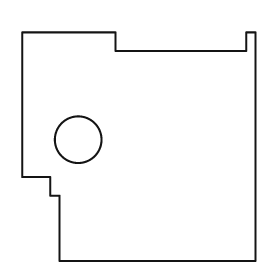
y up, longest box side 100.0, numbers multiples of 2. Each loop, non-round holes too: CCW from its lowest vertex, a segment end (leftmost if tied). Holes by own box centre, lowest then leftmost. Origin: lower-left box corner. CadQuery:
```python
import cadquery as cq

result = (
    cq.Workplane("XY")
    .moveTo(16.0, 0.0)
    .lineTo(100.0, 0.0)
    .lineTo(100.0, 98.0)
    .lineTo(96.0, 98.0)
    .lineTo(96.0, 90.0)
    .lineTo(40.0, 90.0)
    .lineTo(40.0, 98.0)
    .lineTo(0.0, 98.0)
    .lineTo(0.0, 36.0)
    .lineTo(12.0, 36.0)
    .lineTo(12.0, 28.0)
    .lineTo(16.0, 28.0)
    .close()
    .moveTo(24.0, 52.0)
    .circle(10.0)
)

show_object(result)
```